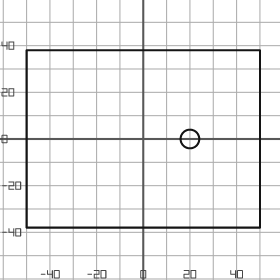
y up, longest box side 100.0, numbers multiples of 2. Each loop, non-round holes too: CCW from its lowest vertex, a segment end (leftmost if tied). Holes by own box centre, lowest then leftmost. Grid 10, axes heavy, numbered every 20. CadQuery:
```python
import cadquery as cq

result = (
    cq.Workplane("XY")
    .moveTo(-50.0, -38.0)
    .lineTo(50.0, -38.0)
    .lineTo(50.0, 38.0)
    .lineTo(-50.0, 38.0)
    .close()
    .moveTo(20.0, 0.0)
    .circle(4.0)
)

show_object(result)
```